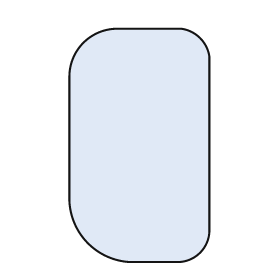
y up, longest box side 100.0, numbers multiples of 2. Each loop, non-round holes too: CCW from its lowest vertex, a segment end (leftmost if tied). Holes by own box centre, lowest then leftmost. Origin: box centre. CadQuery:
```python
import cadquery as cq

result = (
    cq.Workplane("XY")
    .moveTo(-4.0, -50.0)
    .lineTo(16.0, -50.0)
    .threePointArc((26.0, -46.0), (30.0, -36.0))
    .lineTo(30.0, 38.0)
    .threePointArc((26.0, 46.0), (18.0, 50.0))
    .lineTo(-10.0, 50.0)
    .threePointArc((-24.0, 44.0), (-30.0, 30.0))
    .lineTo(-30.0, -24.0)
    .threePointArc((-22.0, -42.0), (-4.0, -50.0))
    .close()
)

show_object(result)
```